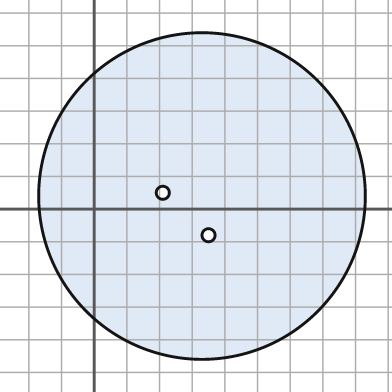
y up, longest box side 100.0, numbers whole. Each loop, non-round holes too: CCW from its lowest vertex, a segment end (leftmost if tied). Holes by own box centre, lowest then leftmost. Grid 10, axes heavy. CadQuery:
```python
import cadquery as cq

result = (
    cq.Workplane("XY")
    .moveTo(33.0, 4.0)
    .circle(50.0)
    .moveTo(35.0, -8.0)
    .circle(2.0)
    .moveTo(21.0, 5.0)
    .circle(2.0)
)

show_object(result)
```